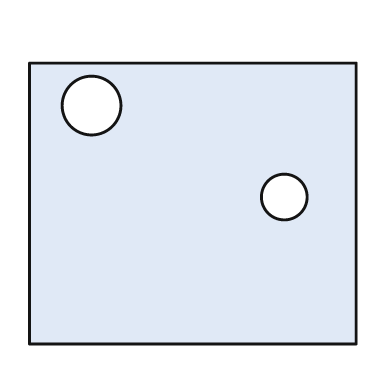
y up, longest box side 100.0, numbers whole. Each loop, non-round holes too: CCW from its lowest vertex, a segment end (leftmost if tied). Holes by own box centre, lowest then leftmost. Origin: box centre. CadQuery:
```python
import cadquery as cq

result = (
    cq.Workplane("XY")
    .moveTo(-50.0, -43.0)
    .lineTo(50.0, -43.0)
    .lineTo(50.0, 43.0)
    .lineTo(-50.0, 43.0)
    .close()
    .moveTo(28.0, 2.0)
    .circle(7.0)
    .moveTo(-31.0, 30.0)
    .circle(9.0)
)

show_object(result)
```